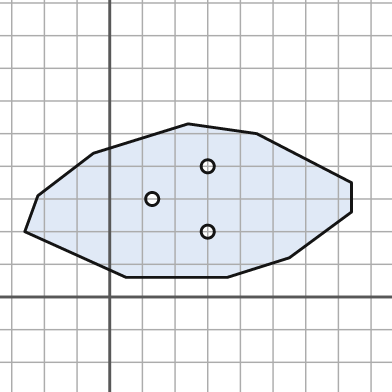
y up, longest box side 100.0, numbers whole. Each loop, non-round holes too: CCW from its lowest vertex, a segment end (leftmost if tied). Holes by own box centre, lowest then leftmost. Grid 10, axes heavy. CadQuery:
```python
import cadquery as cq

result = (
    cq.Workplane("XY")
    .moveTo(5.0, 6.0)
    .lineTo(36.0, 6.0)
    .lineTo(55.0, 12.0)
    .lineTo(74.0, 26.0)
    .lineTo(74.0, 35.0)
    .lineTo(45.0, 50.0)
    .lineTo(24.0, 53.0)
    .lineTo(-5.0, 44.0)
    .lineTo(-22.0, 31.0)
    .lineTo(-26.0, 20.0)
    .close()
    .moveTo(30.0, 20.0)
    .circle(2.0)
    .moveTo(13.0, 30.0)
    .circle(2.0)
    .moveTo(30.0, 40.0)
    .circle(2.0)
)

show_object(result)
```